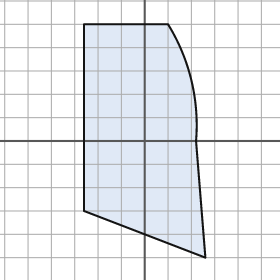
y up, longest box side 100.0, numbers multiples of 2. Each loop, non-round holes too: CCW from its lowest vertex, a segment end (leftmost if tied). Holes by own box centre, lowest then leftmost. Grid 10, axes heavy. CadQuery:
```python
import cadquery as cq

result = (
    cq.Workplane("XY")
    .moveTo(26.0, -50.0)
    .lineTo(22.0, 0.0)
    .threePointArc((20.0, 26.0), (10.0, 50.0))
    .lineTo(-26.0, 50.0)
    .lineTo(-26.0, -30.0)
    .close()
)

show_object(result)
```